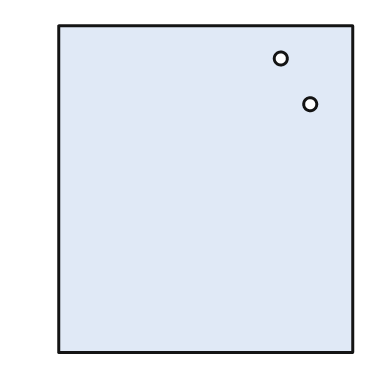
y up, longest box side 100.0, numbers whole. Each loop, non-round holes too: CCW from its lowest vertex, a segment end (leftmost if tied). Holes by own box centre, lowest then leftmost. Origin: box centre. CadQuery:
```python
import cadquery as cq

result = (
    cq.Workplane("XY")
    .moveTo(-45.0, -50.0)
    .lineTo(45.0, -50.0)
    .lineTo(45.0, 50.0)
    .lineTo(-45.0, 50.0)
    .close()
    .moveTo(32.0, 26.0)
    .circle(2.0)
    .moveTo(23.0, 40.0)
    .circle(2.0)
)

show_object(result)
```